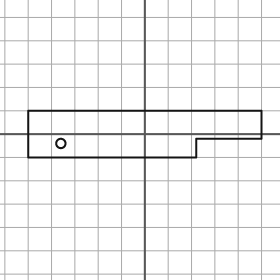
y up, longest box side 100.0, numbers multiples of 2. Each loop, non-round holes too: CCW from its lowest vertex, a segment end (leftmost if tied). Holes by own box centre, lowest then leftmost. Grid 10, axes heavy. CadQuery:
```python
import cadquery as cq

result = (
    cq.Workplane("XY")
    .moveTo(-50.0, -10.0)
    .lineTo(22.0, -10.0)
    .lineTo(22.0, -2.0)
    .lineTo(50.0, -2.0)
    .lineTo(50.0, 10.0)
    .lineTo(-50.0, 10.0)
    .close()
    .moveTo(-36.0, -4.0)
    .circle(2.0)
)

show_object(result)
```